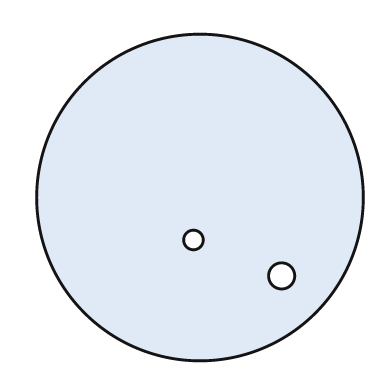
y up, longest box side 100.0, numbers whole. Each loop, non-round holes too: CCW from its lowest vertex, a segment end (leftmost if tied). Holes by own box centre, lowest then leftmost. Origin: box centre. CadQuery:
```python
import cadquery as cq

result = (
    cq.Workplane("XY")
    .moveTo(0.0, 0.0)
    .circle(50.0)
    .moveTo(25.0, -24.0)
    .circle(4.0)
    .moveTo(-2.0, -13.0)
    .circle(3.0)
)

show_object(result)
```